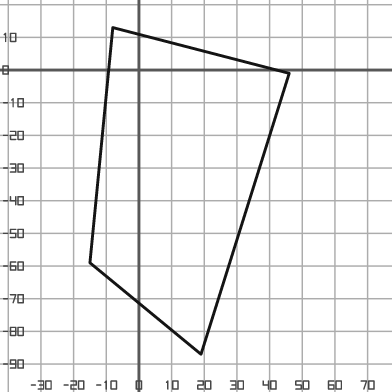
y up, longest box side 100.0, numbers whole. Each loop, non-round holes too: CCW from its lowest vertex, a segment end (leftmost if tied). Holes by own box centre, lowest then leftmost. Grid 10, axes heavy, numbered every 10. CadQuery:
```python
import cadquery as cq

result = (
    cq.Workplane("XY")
    .moveTo(19.0, -87.0)
    .lineTo(46.0, -1.0)
    .lineTo(-8.0, 13.0)
    .lineTo(-15.0, -59.0)
    .close()
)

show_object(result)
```